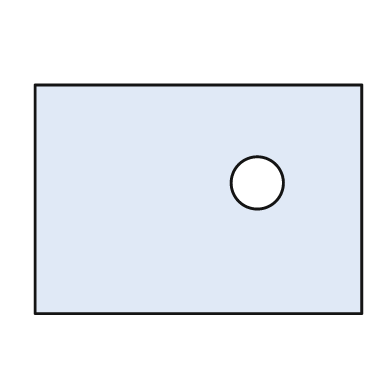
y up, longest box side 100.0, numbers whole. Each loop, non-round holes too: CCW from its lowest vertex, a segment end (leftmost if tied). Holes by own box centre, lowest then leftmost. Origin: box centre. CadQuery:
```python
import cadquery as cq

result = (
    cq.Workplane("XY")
    .moveTo(-50.0, -35.0)
    .lineTo(50.0, -35.0)
    .lineTo(50.0, 35.0)
    .lineTo(-50.0, 35.0)
    .close()
    .moveTo(18.0, 5.0)
    .circle(8.0)
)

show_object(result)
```